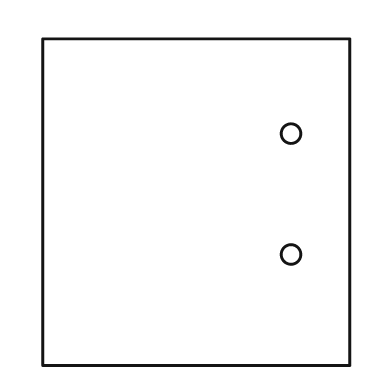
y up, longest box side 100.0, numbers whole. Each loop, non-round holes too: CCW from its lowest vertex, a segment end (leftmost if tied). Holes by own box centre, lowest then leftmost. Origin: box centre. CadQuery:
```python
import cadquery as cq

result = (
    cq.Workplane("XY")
    .moveTo(-47.0, -50.0)
    .lineTo(47.0, -50.0)
    .lineTo(47.0, 50.0)
    .lineTo(-47.0, 50.0)
    .close()
    .moveTo(29.0, -16.0)
    .circle(3.0)
    .moveTo(29.0, 21.0)
    .circle(3.0)
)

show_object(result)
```